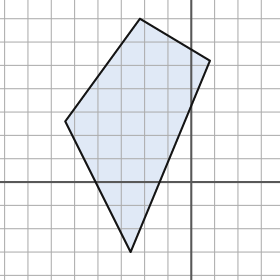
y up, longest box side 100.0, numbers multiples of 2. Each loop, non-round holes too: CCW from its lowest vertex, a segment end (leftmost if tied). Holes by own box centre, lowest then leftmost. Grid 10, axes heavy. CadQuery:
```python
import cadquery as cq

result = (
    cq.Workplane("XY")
    .moveTo(-26.0, -30.0)
    .lineTo(8.0, 52.0)
    .lineTo(-22.0, 70.0)
    .lineTo(-54.0, 26.0)
    .close()
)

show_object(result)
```